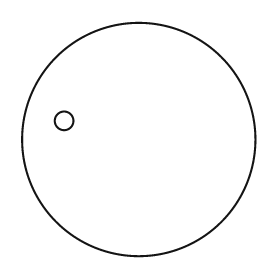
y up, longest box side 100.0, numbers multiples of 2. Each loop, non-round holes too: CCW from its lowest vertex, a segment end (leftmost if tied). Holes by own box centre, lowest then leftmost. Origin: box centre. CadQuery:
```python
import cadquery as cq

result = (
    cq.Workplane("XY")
    .moveTo(0.0, 0.0)
    .circle(50.0)
    .moveTo(-32.0, 8.0)
    .circle(4.0)
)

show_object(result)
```